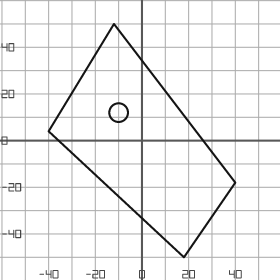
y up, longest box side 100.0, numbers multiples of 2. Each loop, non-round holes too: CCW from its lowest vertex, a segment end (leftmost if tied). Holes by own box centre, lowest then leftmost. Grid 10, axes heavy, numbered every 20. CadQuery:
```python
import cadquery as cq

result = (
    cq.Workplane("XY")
    .moveTo(18.0, -50.0)
    .lineTo(40.0, -18.0)
    .lineTo(-12.0, 50.0)
    .lineTo(-40.0, 4.0)
    .close()
    .moveTo(-10.0, 12.0)
    .circle(4.0)
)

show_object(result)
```